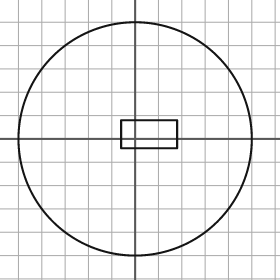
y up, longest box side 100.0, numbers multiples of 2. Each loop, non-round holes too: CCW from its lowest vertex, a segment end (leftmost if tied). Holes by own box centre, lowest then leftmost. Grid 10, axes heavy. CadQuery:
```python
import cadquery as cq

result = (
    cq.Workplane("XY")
    .moveTo(0.0, 0.0)
    .circle(50.0)
    .moveTo(-6.0, -4.0)
    .lineTo(18.0, -4.0)
    .lineTo(18.0, 8.0)
    .lineTo(-6.0, 8.0)
    .close()
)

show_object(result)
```